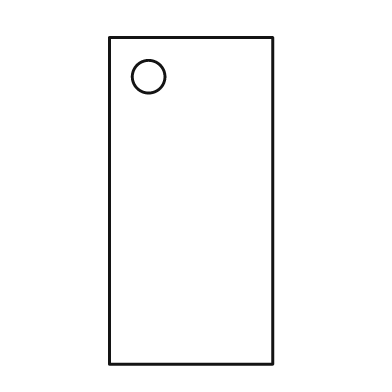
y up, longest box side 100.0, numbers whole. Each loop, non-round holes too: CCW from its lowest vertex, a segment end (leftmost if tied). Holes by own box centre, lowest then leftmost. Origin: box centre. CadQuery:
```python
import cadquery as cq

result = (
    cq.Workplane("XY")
    .moveTo(-25.0, -50.0)
    .lineTo(25.0, -50.0)
    .lineTo(25.0, 50.0)
    .lineTo(-25.0, 50.0)
    .close()
    .moveTo(-13.0, 38.0)
    .circle(5.0)
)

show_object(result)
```